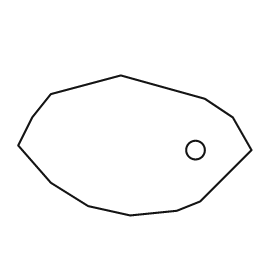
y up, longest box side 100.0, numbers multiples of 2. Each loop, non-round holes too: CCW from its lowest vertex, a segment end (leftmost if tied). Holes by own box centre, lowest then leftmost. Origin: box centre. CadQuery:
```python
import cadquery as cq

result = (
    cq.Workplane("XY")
    .moveTo(-2.0, -30.0)
    .lineTo(18.0, -28.0)
    .lineTo(28.0, -24.0)
    .lineTo(50.0, -2.0)
    .lineTo(42.0, 12.0)
    .lineTo(30.0, 20.0)
    .lineTo(-6.0, 30.0)
    .lineTo(-36.0, 22.0)
    .lineTo(-44.0, 12.0)
    .lineTo(-50.0, 0.0)
    .lineTo(-36.0, -16.0)
    .lineTo(-20.0, -26.0)
    .close()
    .moveTo(26.0, -2.0)
    .circle(4.0)
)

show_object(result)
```